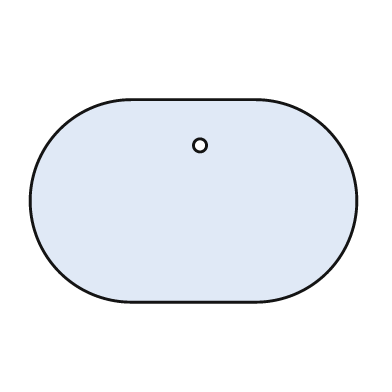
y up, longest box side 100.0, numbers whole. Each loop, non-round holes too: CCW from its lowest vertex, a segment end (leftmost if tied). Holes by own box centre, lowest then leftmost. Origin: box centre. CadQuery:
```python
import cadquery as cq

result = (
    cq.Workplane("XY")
    .moveTo(-19.0, -31.0)
    .lineTo(19.0, -31.0)
    .threePointArc((50.0, 0.0), (19.0, 31.0))
    .lineTo(-19.0, 31.0)
    .threePointArc((-50.0, 0.0), (-19.0, -31.0))
    .close()
    .moveTo(2.0, 17.0)
    .circle(2.0)
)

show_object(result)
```